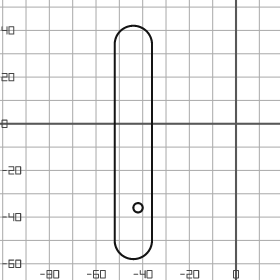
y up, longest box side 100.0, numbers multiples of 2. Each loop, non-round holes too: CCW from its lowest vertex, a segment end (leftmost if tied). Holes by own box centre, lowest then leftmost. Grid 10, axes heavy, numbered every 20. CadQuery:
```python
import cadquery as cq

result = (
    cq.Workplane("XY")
    .moveTo(-52.0, -50.0)
    .threePointArc((-44.0, -58.0), (-36.0, -50.0))
    .lineTo(-36.0, 34.0)
    .threePointArc((-44.0, 42.0), (-52.0, 34.0))
    .close()
    .moveTo(-42.0, -36.0)
    .circle(2.0)
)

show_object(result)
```